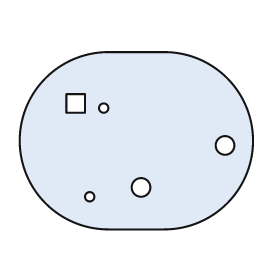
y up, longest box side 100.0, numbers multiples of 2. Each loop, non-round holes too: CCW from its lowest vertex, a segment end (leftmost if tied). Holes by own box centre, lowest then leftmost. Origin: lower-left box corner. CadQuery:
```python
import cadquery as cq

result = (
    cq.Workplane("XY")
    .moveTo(38.0, 0.0)
    .lineTo(62.0, 0.0)
    .threePointArc((100.0, 38.0), (62.0, 76.0))
    .lineTo(38.0, 76.0)
    .threePointArc((0.0, 38.0), (38.0, 0.0))
    .close()
    .moveTo(30.0, 14.0)
    .circle(2.0)
    .moveTo(52.0, 18.0)
    .circle(4.0)
    .moveTo(88.0, 36.0)
    .circle(4.0)
    .moveTo(36.0, 52.0)
    .circle(2.0)
    .moveTo(20.0, 50.0)
    .lineTo(28.0, 50.0)
    .lineTo(28.0, 58.0)
    .lineTo(20.0, 58.0)
    .close()
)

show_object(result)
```